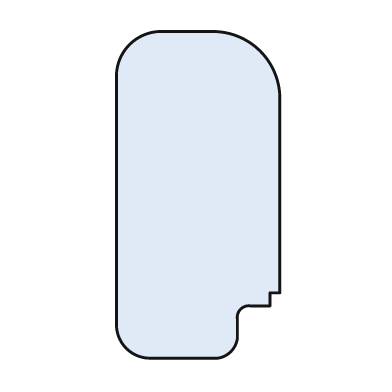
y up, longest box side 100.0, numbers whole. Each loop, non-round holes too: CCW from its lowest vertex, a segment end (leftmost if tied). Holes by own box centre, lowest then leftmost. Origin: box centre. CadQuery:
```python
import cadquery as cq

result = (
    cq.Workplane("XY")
    .moveTo(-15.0, -50.0)
    .lineTo(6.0, -50.0)
    .threePointArc((10.0, -48.0), (12.0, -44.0))
    .lineTo(12.0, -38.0)
    .threePointArc((13.0, -35.0), (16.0, -34.0))
    .lineTo(22.0, -34.0)
    .lineTo(22.0, -30.0)
    .lineTo(25.0, -30.0)
    .lineTo(25.0, 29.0)
    .threePointArc((19.0, 44.0), (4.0, 50.0))
    .lineTo(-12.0, 50.0)
    .threePointArc((-21.0, 46.0), (-25.0, 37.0))
    .lineTo(-25.0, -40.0)
    .threePointArc((-22.0, -47.0), (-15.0, -50.0))
    .close()
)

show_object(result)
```